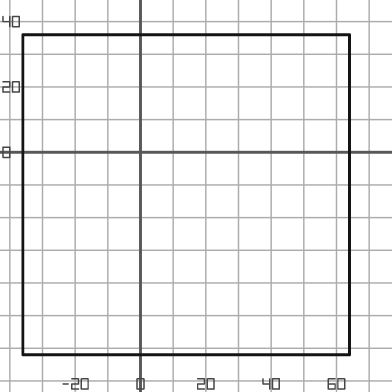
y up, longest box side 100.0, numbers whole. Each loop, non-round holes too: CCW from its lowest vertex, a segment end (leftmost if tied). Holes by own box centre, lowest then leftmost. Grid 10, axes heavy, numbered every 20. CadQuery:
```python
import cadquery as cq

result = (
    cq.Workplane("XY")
    .moveTo(-36.0, -62.0)
    .lineTo(64.0, -62.0)
    .lineTo(64.0, 36.0)
    .lineTo(-36.0, 36.0)
    .close()
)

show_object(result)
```